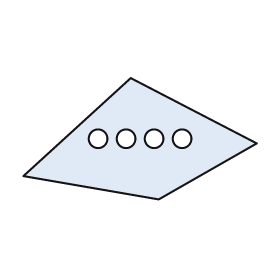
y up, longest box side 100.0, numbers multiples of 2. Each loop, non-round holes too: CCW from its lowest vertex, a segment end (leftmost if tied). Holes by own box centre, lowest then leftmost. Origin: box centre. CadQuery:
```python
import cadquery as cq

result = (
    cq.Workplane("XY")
    .moveTo(8.0, -26.0)
    .lineTo(50.0, -2.0)
    .lineTo(-4.0, 26.0)
    .lineTo(-50.0, -16.0)
    .close()
    .moveTo(-18.0, 0.0)
    .circle(4.0)
    .moveTo(-6.0, 0.0)
    .circle(4.0)
    .moveTo(6.0, 0.0)
    .circle(4.0)
    .moveTo(18.0, 0.0)
    .circle(4.0)
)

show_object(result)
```